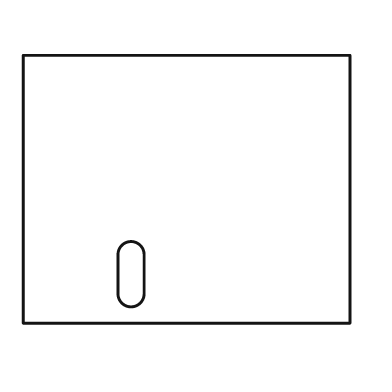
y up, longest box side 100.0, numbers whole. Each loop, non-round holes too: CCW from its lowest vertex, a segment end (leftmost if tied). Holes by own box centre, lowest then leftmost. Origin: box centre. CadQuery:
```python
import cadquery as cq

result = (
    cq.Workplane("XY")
    .moveTo(-50.0, -41.0)
    .lineTo(50.0, -41.0)
    .lineTo(50.0, 41.0)
    .lineTo(-50.0, 41.0)
    .close()
    .moveTo(-21.0, -32.0)
    .threePointArc((-17.0, -36.0), (-13.0, -32.0))
    .lineTo(-13.0, -20.0)
    .threePointArc((-17.0, -16.0), (-21.0, -20.0))
    .close()
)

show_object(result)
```